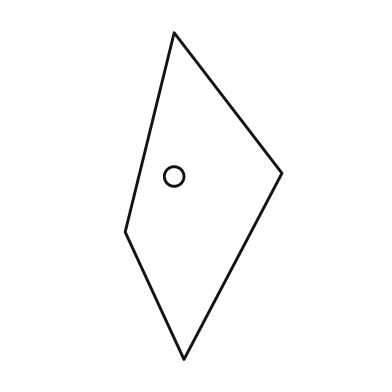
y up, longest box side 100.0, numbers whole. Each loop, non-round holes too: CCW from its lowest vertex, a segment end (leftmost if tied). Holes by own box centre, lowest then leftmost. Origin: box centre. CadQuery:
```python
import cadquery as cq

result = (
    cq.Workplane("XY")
    .moveTo(-6.0, -50.0)
    .lineTo(24.0, 7.0)
    .lineTo(-9.0, 50.0)
    .lineTo(-24.0, -11.0)
    .close()
    .moveTo(-9.0, 6.0)
    .circle(3.0)
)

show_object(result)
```